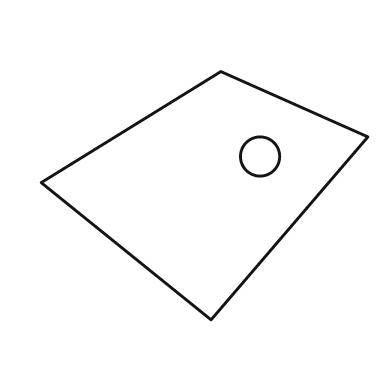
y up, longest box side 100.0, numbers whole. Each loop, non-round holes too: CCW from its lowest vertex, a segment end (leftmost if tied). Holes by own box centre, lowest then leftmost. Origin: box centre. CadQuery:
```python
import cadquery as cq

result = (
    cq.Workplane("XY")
    .moveTo(2.0, -38.0)
    .lineTo(50.0, 18.0)
    .lineTo(5.0, 38.0)
    .lineTo(-50.0, 4.0)
    .close()
    .moveTo(17.0, 12.0)
    .circle(6.0)
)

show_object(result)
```